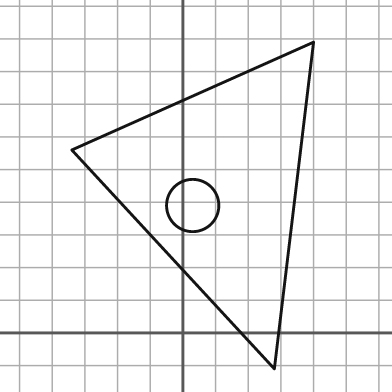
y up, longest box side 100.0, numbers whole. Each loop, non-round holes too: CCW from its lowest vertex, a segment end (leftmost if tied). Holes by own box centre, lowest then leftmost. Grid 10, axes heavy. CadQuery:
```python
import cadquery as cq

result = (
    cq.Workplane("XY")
    .moveTo(28.0, -11.0)
    .lineTo(40.0, 89.0)
    .lineTo(-34.0, 56.0)
    .close()
    .moveTo(3.0, 39.0)
    .circle(8.0)
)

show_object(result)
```